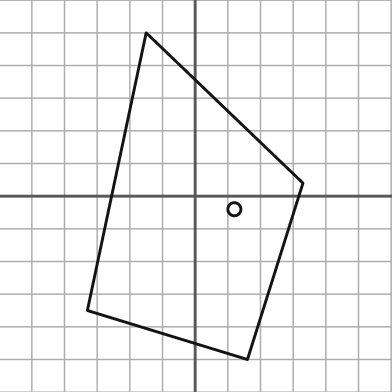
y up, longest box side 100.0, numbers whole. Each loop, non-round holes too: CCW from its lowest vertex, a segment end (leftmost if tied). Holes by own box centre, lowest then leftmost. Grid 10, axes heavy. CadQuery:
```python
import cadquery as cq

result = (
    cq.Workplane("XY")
    .moveTo(16.0, -50.0)
    .lineTo(33.0, 4.0)
    .lineTo(-15.0, 50.0)
    .lineTo(-33.0, -35.0)
    .close()
    .moveTo(12.0, -4.0)
    .circle(2.0)
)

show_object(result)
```